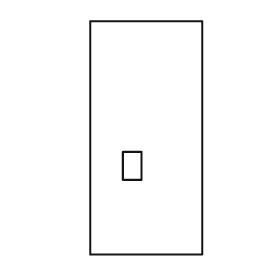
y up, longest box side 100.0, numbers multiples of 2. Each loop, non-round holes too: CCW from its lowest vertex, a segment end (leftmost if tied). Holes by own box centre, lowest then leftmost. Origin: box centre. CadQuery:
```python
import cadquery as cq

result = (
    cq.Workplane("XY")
    .moveTo(-24.0, -50.0)
    .lineTo(24.0, -50.0)
    .lineTo(24.0, 50.0)
    .lineTo(-24.0, 50.0)
    .close()
    .moveTo(-10.0, -18.0)
    .lineTo(-2.0, -18.0)
    .lineTo(-2.0, -6.0)
    .lineTo(-10.0, -6.0)
    .close()
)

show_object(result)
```